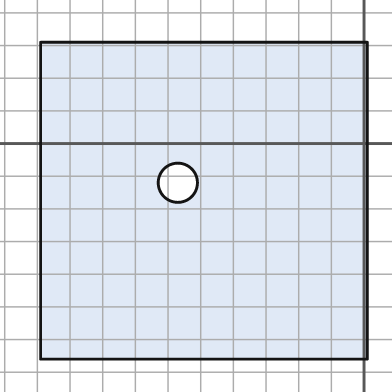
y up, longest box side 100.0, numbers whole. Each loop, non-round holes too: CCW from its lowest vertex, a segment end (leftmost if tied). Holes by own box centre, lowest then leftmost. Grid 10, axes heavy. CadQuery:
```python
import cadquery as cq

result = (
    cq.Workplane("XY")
    .moveTo(-99.0, -66.0)
    .lineTo(1.0, -66.0)
    .lineTo(1.0, 31.0)
    .lineTo(-99.0, 31.0)
    .close()
    .moveTo(-57.0, -12.0)
    .circle(6.0)
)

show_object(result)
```